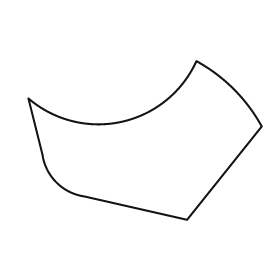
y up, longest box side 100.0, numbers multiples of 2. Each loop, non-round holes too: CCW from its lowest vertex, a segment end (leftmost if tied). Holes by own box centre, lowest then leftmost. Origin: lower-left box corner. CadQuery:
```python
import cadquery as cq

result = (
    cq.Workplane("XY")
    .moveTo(68.0, 0.0)
    .lineTo(100.0, 40.0)
    .threePointArc((88.0, 56.0), (72.0, 68.0))
    .threePointArc((40.0, 42.0), (0.0, 52.0))
    .lineTo(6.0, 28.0)
    .threePointArc((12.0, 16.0), (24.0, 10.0))
    .close()
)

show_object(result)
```